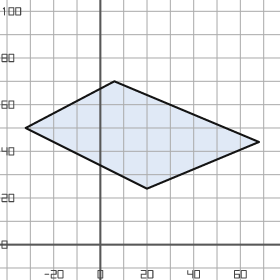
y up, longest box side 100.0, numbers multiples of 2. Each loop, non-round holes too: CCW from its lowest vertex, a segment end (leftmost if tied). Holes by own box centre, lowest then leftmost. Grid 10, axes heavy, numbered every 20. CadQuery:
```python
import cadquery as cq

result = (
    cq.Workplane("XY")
    .moveTo(20.0, 24.0)
    .lineTo(68.0, 44.0)
    .lineTo(6.0, 70.0)
    .lineTo(-32.0, 50.0)
    .close()
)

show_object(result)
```